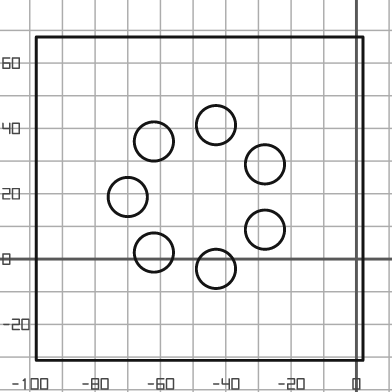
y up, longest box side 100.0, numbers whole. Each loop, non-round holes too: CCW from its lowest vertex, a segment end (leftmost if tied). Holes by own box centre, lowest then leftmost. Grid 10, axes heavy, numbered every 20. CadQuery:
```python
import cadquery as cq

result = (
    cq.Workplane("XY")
    .moveTo(-98.0, -31.0)
    .lineTo(2.0, -31.0)
    .lineTo(2.0, 68.0)
    .lineTo(-98.0, 68.0)
    .close()
    .moveTo(-43.0, -3.0)
    .circle(6.0)
    .moveTo(-62.0, 2.0)
    .circle(6.0)
    .moveTo(-28.0, 9.0)
    .circle(6.0)
    .moveTo(-70.0, 19.0)
    .circle(6.0)
    .moveTo(-28.0, 29.0)
    .circle(6.0)
    .moveTo(-62.0, 36.0)
    .circle(6.0)
    .moveTo(-43.0, 41.0)
    .circle(6.0)
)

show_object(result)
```